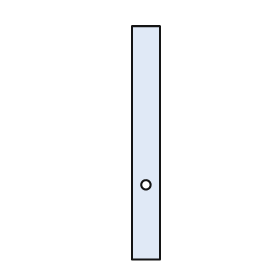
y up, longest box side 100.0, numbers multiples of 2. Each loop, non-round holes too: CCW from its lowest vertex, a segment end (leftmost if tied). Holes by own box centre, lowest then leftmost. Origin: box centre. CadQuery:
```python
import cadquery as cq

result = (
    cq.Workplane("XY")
    .moveTo(-6.0, -50.0)
    .lineTo(6.0, -50.0)
    .lineTo(6.0, 50.0)
    .lineTo(-6.0, 50.0)
    .close()
    .moveTo(0.0, -18.0)
    .circle(2.0)
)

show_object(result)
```